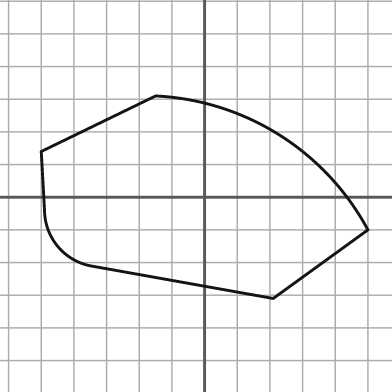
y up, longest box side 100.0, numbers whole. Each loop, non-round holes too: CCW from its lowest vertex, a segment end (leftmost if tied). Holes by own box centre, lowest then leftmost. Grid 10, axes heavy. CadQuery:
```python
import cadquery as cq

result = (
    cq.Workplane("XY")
    .moveTo(21.0, -31.0)
    .lineTo(50.0, -10.0)
    .threePointArc((23.0, 19.0), (-15.0, 31.0))
    .lineTo(-50.0, 14.0)
    .lineTo(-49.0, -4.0)
    .threePointArc((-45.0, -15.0), (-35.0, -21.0))
    .close()
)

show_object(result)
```